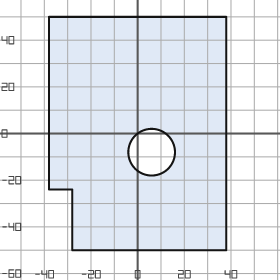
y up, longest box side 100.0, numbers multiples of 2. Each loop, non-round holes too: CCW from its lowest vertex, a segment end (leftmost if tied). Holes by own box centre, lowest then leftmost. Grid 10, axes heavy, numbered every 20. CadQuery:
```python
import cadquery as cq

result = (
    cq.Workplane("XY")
    .moveTo(-28.0, -50.0)
    .lineTo(38.0, -50.0)
    .lineTo(38.0, 50.0)
    .lineTo(-38.0, 50.0)
    .lineTo(-38.0, -24.0)
    .lineTo(-28.0, -24.0)
    .close()
    .moveTo(6.0, -8.0)
    .circle(10.0)
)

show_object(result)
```